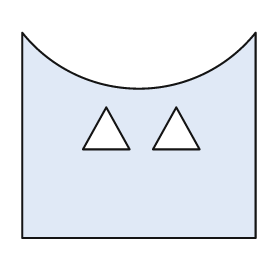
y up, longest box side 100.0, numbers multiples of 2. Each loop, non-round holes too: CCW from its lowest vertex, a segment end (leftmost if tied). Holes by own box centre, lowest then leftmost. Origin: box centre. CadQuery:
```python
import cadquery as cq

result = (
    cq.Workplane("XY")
    .moveTo(-50.0, -44.0)
    .lineTo(50.0, -44.0)
    .lineTo(50.0, 44.0)
    .threePointArc((0.0, 20.0), (-50.0, 44.0))
    .close()
    .moveTo(-24.0, -6.0)
    .lineTo(-4.0, -6.0)
    .lineTo(-14.0, 12.0)
    .close()
    .moveTo(6.0, -6.0)
    .lineTo(26.0, -6.0)
    .lineTo(16.0, 12.0)
    .close()
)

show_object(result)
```